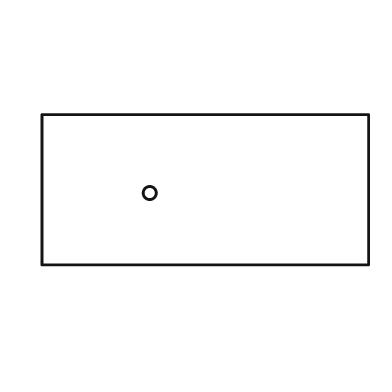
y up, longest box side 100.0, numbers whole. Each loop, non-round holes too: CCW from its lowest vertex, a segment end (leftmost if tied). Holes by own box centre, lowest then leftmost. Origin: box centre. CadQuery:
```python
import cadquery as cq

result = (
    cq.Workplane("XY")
    .moveTo(-50.0, -23.0)
    .lineTo(50.0, -23.0)
    .lineTo(50.0, 23.0)
    .lineTo(-50.0, 23.0)
    .close()
    .moveTo(-17.0, -1.0)
    .circle(2.0)
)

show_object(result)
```